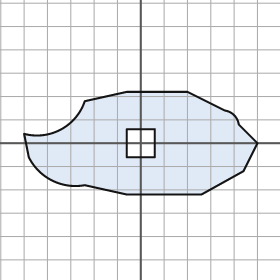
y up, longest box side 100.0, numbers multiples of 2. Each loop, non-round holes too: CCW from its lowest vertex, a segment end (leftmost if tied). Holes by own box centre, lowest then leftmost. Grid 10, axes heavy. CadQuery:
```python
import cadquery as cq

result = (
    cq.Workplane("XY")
    .moveTo(-6.0, -22.0)
    .lineTo(26.0, -22.0)
    .lineTo(44.0, -12.0)
    .lineTo(50.0, 0.0)
    .lineTo(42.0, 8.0)
    .threePointArc((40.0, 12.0), (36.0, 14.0))
    .lineTo(20.0, 22.0)
    .lineTo(-6.0, 22.0)
    .lineTo(-24.0, 18.0)
    .threePointArc((-34.0, 6.0), (-50.0, 4.0))
    .lineTo(-48.0, -6.0)
    .threePointArc((-38.0, -16.0), (-24.0, -18.0))
    .close()
    .moveTo(-6.0, -6.0)
    .lineTo(6.0, -6.0)
    .lineTo(6.0, 6.0)
    .lineTo(-6.0, 6.0)
    .close()
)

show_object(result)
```